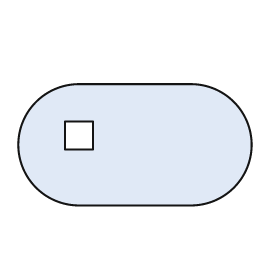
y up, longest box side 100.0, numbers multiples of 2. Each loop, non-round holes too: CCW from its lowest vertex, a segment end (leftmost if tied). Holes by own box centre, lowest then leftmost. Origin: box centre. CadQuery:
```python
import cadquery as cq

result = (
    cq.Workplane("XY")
    .moveTo(-24.0, -26.0)
    .lineTo(24.0, -26.0)
    .threePointArc((50.0, 0.0), (24.0, 26.0))
    .lineTo(-24.0, 26.0)
    .threePointArc((-50.0, 0.0), (-24.0, -26.0))
    .close()
    .moveTo(-30.0, -2.0)
    .lineTo(-18.0, -2.0)
    .lineTo(-18.0, 10.0)
    .lineTo(-30.0, 10.0)
    .close()
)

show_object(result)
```